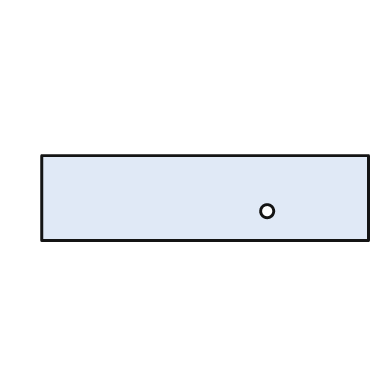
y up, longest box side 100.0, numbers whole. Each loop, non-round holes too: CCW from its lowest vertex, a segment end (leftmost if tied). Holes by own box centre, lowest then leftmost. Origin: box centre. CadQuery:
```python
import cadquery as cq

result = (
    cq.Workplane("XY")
    .moveTo(-50.0, -13.0)
    .lineTo(50.0, -13.0)
    .lineTo(50.0, 13.0)
    .lineTo(-50.0, 13.0)
    .close()
    .moveTo(19.0, -4.0)
    .circle(2.0)
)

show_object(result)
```